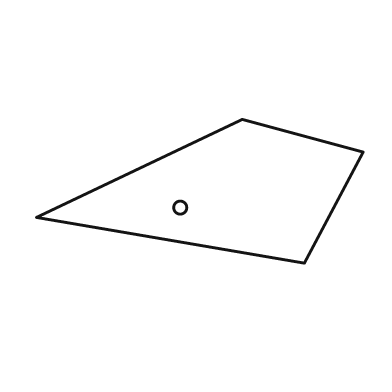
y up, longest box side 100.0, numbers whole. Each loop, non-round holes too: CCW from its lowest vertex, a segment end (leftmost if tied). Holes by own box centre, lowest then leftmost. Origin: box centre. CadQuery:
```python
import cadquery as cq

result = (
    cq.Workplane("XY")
    .moveTo(32.0, -22.0)
    .lineTo(50.0, 12.0)
    .lineTo(13.0, 22.0)
    .lineTo(-50.0, -8.0)
    .close()
    .moveTo(-6.0, -5.0)
    .circle(2.0)
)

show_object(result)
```